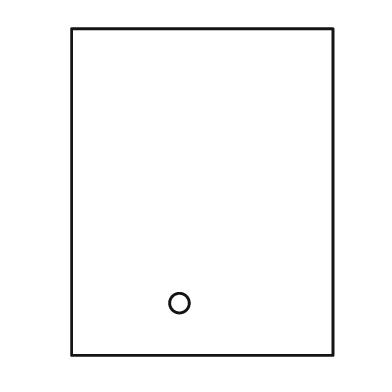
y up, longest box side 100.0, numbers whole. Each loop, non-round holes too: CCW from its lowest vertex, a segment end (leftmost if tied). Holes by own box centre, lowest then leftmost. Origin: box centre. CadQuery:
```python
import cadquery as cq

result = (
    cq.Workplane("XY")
    .moveTo(-40.0, -50.0)
    .lineTo(40.0, -50.0)
    .lineTo(40.0, 50.0)
    .lineTo(-40.0, 50.0)
    .close()
    .moveTo(-7.0, -34.0)
    .circle(3.0)
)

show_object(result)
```